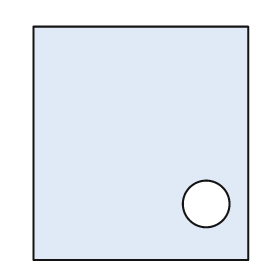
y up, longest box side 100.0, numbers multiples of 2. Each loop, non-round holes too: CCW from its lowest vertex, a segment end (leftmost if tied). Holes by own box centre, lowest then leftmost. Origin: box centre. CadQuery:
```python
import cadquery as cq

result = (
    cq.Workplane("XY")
    .moveTo(-46.0, -50.0)
    .lineTo(46.0, -50.0)
    .lineTo(46.0, 50.0)
    .lineTo(-46.0, 50.0)
    .close()
    .moveTo(28.0, -26.0)
    .circle(10.0)
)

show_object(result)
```